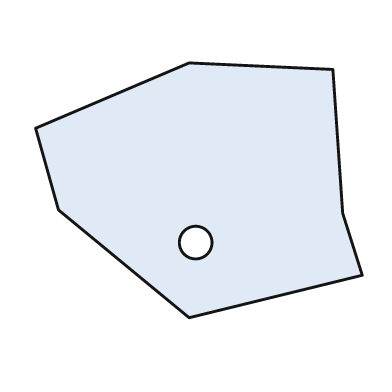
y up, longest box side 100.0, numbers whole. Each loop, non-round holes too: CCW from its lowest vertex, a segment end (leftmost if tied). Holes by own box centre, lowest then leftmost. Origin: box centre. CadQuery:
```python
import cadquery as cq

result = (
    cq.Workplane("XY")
    .moveTo(-3.0, -39.0)
    .lineTo(50.0, -26.0)
    .lineTo(44.0, -7.0)
    .lineTo(41.0, 37.0)
    .lineTo(-3.0, 39.0)
    .lineTo(-50.0, 19.0)
    .lineTo(-43.0, -6.0)
    .close()
    .moveTo(-1.0, -16.0)
    .circle(5.0)
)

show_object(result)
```